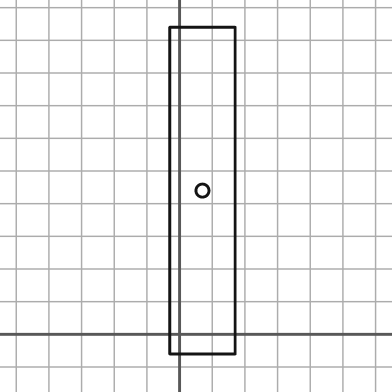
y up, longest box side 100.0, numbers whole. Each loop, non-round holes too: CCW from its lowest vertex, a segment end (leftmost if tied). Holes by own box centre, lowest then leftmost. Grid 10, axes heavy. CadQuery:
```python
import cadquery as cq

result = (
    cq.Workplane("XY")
    .moveTo(-3.0, -6.0)
    .lineTo(17.0, -6.0)
    .lineTo(17.0, 94.0)
    .lineTo(-3.0, 94.0)
    .close()
    .moveTo(7.0, 44.0)
    .circle(2.0)
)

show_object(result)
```